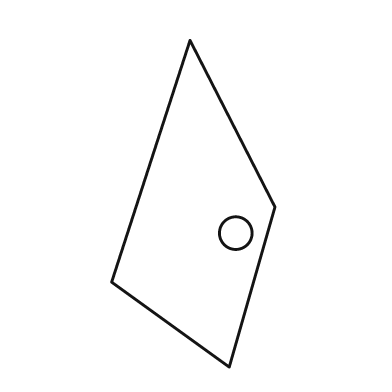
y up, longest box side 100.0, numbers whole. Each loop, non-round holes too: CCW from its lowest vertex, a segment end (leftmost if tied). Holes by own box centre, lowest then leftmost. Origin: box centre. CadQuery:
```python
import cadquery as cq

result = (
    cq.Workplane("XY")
    .moveTo(11.0, -50.0)
    .lineTo(25.0, -1.0)
    .lineTo(-1.0, 50.0)
    .lineTo(-25.0, -24.0)
    .close()
    .moveTo(13.0, -9.0)
    .circle(5.0)
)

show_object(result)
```